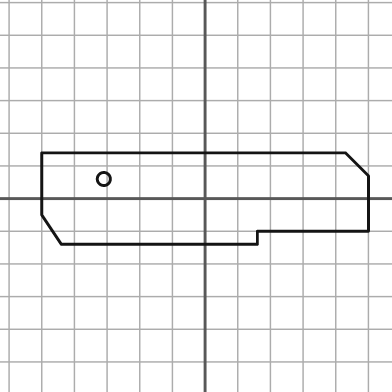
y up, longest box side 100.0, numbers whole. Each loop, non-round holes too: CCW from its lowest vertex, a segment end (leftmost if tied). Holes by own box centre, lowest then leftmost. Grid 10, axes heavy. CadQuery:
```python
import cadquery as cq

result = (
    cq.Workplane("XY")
    .moveTo(-44.0, -14.0)
    .lineTo(16.0, -14.0)
    .lineTo(16.0, -10.0)
    .lineTo(50.0, -10.0)
    .lineTo(50.0, 7.0)
    .lineTo(43.0, 14.0)
    .lineTo(-50.0, 14.0)
    .lineTo(-50.0, -5.0)
    .close()
    .moveTo(-31.0, 6.0)
    .circle(2.0)
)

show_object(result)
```